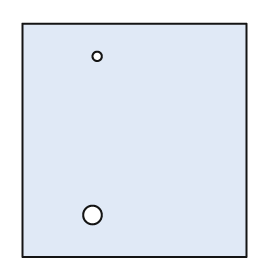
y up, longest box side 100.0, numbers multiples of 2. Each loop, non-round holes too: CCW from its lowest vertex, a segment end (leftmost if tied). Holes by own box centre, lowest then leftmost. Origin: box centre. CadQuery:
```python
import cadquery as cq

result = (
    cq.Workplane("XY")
    .moveTo(-48.0, -50.0)
    .lineTo(48.0, -50.0)
    .lineTo(48.0, 50.0)
    .lineTo(-48.0, 50.0)
    .close()
    .moveTo(-18.0, -32.0)
    .circle(4.0)
    .moveTo(-16.0, 36.0)
    .circle(2.0)
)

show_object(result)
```